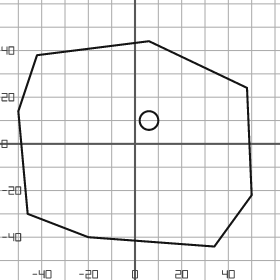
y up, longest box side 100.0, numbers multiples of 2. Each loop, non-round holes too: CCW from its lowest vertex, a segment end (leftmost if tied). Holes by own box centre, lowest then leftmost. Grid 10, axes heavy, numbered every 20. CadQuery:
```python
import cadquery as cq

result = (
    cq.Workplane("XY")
    .moveTo(34.0, -44.0)
    .lineTo(50.0, -22.0)
    .lineTo(48.0, 24.0)
    .lineTo(6.0, 44.0)
    .lineTo(-42.0, 38.0)
    .lineTo(-50.0, 14.0)
    .lineTo(-46.0, -30.0)
    .lineTo(-20.0, -40.0)
    .close()
    .moveTo(6.0, 10.0)
    .circle(4.0)
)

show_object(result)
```